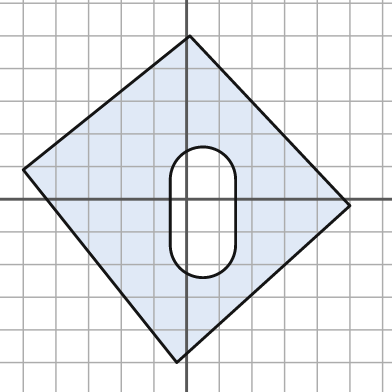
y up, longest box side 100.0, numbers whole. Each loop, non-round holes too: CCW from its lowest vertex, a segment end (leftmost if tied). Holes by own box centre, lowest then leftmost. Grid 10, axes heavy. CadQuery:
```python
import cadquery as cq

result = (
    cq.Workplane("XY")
    .moveTo(-3.0, -50.0)
    .lineTo(50.0, -2.0)
    .lineTo(1.0, 50.0)
    .lineTo(-50.0, 9.0)
    .close()
    .moveTo(-5.0, -14.0)
    .threePointArc((5.0, -24.0), (15.0, -14.0))
    .lineTo(15.0, 6.0)
    .threePointArc((5.0, 16.0), (-5.0, 6.0))
    .close()
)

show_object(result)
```